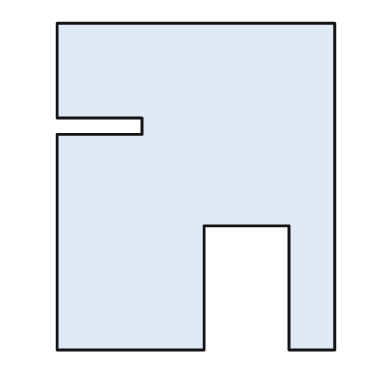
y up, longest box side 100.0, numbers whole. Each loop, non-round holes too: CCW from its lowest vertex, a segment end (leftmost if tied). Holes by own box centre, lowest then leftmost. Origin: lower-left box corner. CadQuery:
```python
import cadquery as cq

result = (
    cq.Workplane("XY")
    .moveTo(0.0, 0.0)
    .lineTo(45.0, 0.0)
    .lineTo(45.0, 38.0)
    .lineTo(71.0, 38.0)
    .lineTo(71.0, 0.0)
    .lineTo(85.0, 0.0)
    .lineTo(85.0, 100.0)
    .lineTo(0.0, 100.0)
    .lineTo(0.0, 71.0)
    .lineTo(26.0, 71.0)
    .lineTo(26.0, 66.0)
    .lineTo(0.0, 66.0)
    .close()
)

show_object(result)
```